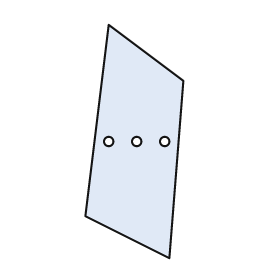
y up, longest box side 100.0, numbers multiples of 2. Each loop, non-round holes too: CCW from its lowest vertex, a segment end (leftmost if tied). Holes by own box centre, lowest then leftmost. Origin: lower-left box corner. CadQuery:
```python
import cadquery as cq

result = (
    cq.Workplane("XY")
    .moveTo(36.0, 0.0)
    .lineTo(42.0, 76.0)
    .lineTo(10.0, 100.0)
    .lineTo(0.0, 18.0)
    .close()
    .moveTo(10.0, 50.0)
    .circle(2.0)
    .moveTo(22.0, 50.0)
    .circle(2.0)
    .moveTo(34.0, 50.0)
    .circle(2.0)
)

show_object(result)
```